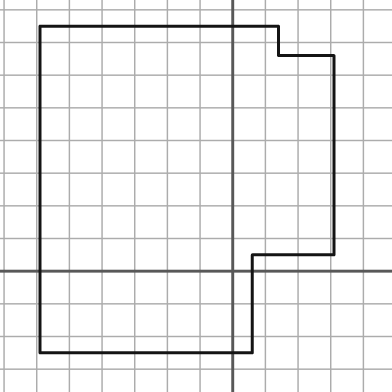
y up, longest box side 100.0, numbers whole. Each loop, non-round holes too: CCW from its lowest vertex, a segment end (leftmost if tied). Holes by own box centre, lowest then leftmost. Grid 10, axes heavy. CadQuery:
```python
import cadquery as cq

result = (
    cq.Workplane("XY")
    .moveTo(-59.0, -25.0)
    .lineTo(6.0, -25.0)
    .lineTo(6.0, 5.0)
    .lineTo(31.0, 5.0)
    .lineTo(31.0, 66.0)
    .lineTo(14.0, 66.0)
    .lineTo(14.0, 75.0)
    .lineTo(-59.0, 75.0)
    .close()
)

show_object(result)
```